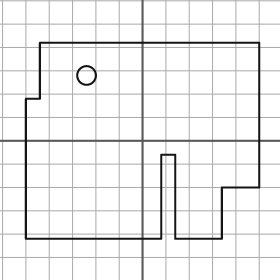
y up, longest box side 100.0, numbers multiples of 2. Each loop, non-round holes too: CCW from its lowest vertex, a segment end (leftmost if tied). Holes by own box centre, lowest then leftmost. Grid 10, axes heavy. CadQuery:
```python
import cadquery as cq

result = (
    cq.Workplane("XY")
    .moveTo(-50.0, -42.0)
    .lineTo(8.0, -42.0)
    .lineTo(8.0, -6.0)
    .lineTo(14.0, -6.0)
    .lineTo(14.0, -42.0)
    .lineTo(34.0, -42.0)
    .lineTo(34.0, -20.0)
    .lineTo(50.0, -20.0)
    .lineTo(50.0, 42.0)
    .lineTo(-44.0, 42.0)
    .lineTo(-44.0, 18.0)
    .lineTo(-50.0, 18.0)
    .close()
    .moveTo(-24.0, 28.0)
    .circle(4.0)
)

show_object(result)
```